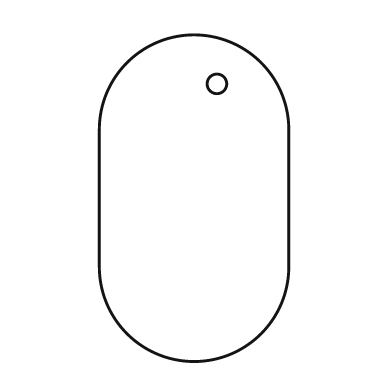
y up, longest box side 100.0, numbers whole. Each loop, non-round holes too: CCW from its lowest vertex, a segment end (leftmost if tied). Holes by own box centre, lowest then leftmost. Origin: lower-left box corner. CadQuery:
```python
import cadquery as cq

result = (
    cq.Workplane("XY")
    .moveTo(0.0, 29.0)
    .threePointArc((29.0, 0.0), (58.0, 29.0))
    .lineTo(58.0, 71.0)
    .threePointArc((29.0, 100.0), (0.0, 71.0))
    .close()
    .moveTo(36.0, 85.0)
    .circle(3.0)
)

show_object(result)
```